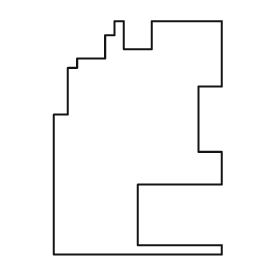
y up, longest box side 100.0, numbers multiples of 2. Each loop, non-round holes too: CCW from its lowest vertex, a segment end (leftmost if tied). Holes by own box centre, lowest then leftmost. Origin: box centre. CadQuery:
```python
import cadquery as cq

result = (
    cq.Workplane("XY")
    .moveTo(-36.0, -50.0)
    .lineTo(36.0, -50.0)
    .lineTo(36.0, -46.0)
    .lineTo(0.0, -46.0)
    .lineTo(0.0, -20.0)
    .lineTo(36.0, -20.0)
    .lineTo(36.0, -6.0)
    .lineTo(26.0, -6.0)
    .lineTo(26.0, 22.0)
    .lineTo(36.0, 22.0)
    .lineTo(36.0, 50.0)
    .lineTo(6.0, 50.0)
    .lineTo(6.0, 38.0)
    .lineTo(-6.0, 38.0)
    .lineTo(-6.0, 50.0)
    .lineTo(-10.0, 50.0)
    .lineTo(-10.0, 44.0)
    .lineTo(-14.0, 44.0)
    .lineTo(-14.0, 34.0)
    .lineTo(-26.0, 34.0)
    .lineTo(-26.0, 30.0)
    .lineTo(-30.0, 30.0)
    .lineTo(-30.0, 10.0)
    .lineTo(-36.0, 10.0)
    .close()
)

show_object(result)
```